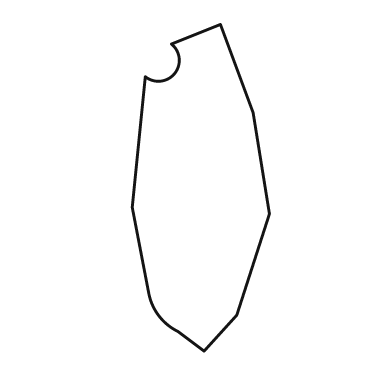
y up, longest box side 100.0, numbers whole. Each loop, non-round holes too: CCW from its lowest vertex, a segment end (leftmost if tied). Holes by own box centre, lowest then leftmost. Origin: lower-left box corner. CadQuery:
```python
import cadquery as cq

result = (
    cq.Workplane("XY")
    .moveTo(22.0, 0.0)
    .lineTo(32.0, 11.0)
    .lineTo(42.0, 42.0)
    .lineTo(37.0, 73.0)
    .lineTo(27.0, 100.0)
    .lineTo(12.0, 94.0)
    .threePointArc((13.0, 85.0), (4.0, 84.0))
    .lineTo(0.0, 44.0)
    .lineTo(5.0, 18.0)
    .threePointArc((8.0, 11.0), (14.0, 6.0))
    .close()
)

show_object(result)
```